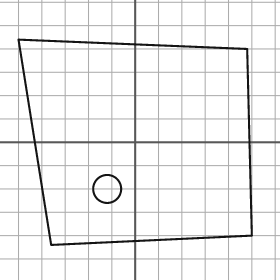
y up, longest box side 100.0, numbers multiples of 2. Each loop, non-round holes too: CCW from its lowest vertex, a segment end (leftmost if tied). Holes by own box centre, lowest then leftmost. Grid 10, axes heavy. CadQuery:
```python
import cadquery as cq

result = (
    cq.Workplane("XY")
    .moveTo(-36.0, -44.0)
    .lineTo(50.0, -40.0)
    .lineTo(48.0, 40.0)
    .lineTo(-50.0, 44.0)
    .close()
    .moveTo(-12.0, -20.0)
    .circle(6.0)
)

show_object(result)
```